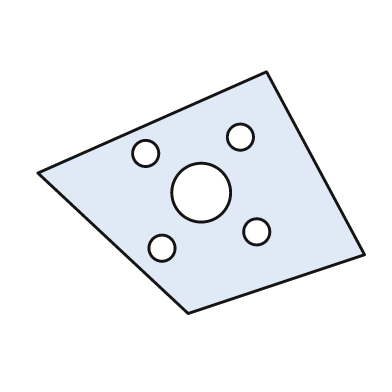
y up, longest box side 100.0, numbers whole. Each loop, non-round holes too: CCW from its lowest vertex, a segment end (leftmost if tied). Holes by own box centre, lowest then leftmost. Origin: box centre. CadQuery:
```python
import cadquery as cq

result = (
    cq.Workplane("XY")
    .moveTo(-4.0, -37.0)
    .lineTo(50.0, -19.0)
    .lineTo(20.0, 37.0)
    .lineTo(-50.0, 6.0)
    .close()
    .moveTo(-12.0, -17.0)
    .circle(4.0)
    .moveTo(17.0, -12.0)
    .circle(4.0)
    .moveTo(0.0, 0.0)
    .circle(9.0)
    .moveTo(-17.0, 12.0)
    .circle(4.0)
    .moveTo(12.0, 17.0)
    .circle(4.0)
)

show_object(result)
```